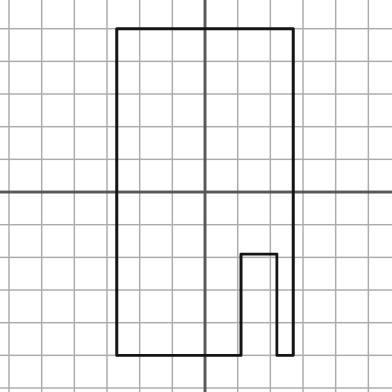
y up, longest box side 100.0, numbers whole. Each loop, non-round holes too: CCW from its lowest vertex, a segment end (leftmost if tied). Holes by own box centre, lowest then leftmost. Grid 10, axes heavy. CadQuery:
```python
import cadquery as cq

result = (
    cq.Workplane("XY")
    .moveTo(-27.0, -50.0)
    .lineTo(11.0, -50.0)
    .lineTo(11.0, -19.0)
    .lineTo(22.0, -19.0)
    .lineTo(22.0, -50.0)
    .lineTo(27.0, -50.0)
    .lineTo(27.0, 50.0)
    .lineTo(-27.0, 50.0)
    .close()
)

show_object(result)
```